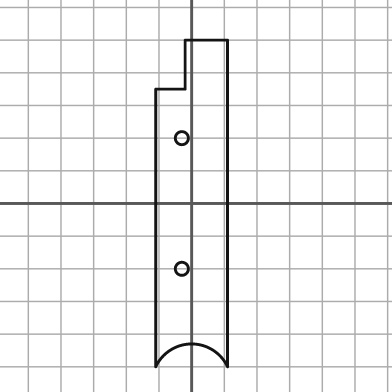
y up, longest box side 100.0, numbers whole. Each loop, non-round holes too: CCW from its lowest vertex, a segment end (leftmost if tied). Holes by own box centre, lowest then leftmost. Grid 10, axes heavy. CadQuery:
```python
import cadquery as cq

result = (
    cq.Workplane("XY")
    .moveTo(-11.0, -50.0)
    .threePointArc((0.0, -43.0), (11.0, -50.0))
    .lineTo(11.0, 50.0)
    .lineTo(-2.0, 50.0)
    .lineTo(-2.0, 35.0)
    .lineTo(-11.0, 35.0)
    .close()
    .moveTo(-3.0, -20.0)
    .circle(2.0)
    .moveTo(-3.0, 20.0)
    .circle(2.0)
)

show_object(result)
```